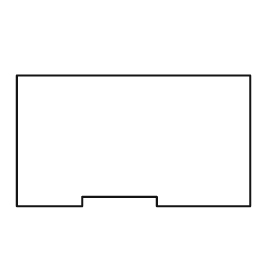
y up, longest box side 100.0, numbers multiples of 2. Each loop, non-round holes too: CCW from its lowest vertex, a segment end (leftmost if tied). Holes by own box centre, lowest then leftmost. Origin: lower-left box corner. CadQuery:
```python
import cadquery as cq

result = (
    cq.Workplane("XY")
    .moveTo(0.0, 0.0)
    .lineTo(28.0, 0.0)
    .lineTo(28.0, 4.0)
    .lineTo(60.0, 4.0)
    .lineTo(60.0, 0.0)
    .lineTo(100.0, 0.0)
    .lineTo(100.0, 56.0)
    .lineTo(0.0, 56.0)
    .close()
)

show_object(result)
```